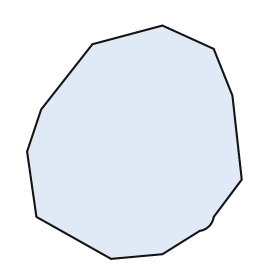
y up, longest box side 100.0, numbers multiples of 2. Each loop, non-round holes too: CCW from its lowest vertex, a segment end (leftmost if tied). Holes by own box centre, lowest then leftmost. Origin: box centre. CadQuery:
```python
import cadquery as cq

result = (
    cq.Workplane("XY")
    .moveTo(-10.0, -50.0)
    .lineTo(12.0, -48.0)
    .lineTo(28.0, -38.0)
    .threePointArc((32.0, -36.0), (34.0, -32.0))
    .lineTo(46.0, -16.0)
    .lineTo(42.0, 20.0)
    .lineTo(34.0, 40.0)
    .lineTo(12.0, 50.0)
    .lineTo(-18.0, 42.0)
    .lineTo(-40.0, 14.0)
    .lineTo(-46.0, -4.0)
    .lineTo(-42.0, -32.0)
    .close()
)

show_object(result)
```